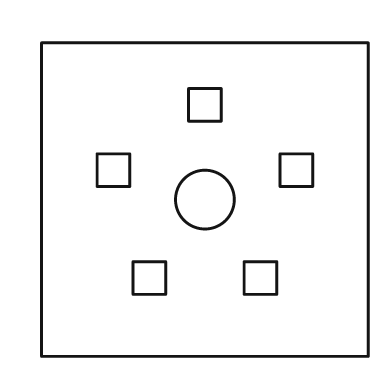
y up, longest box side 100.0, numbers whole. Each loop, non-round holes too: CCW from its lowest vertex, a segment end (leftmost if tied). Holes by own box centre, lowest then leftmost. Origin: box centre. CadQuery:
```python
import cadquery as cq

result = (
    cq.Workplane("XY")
    .moveTo(-50.0, -48.0)
    .lineTo(50.0, -48.0)
    .lineTo(50.0, 48.0)
    .lineTo(-50.0, 48.0)
    .close()
    .moveTo(-22.0, -29.0)
    .lineTo(-12.0, -29.0)
    .lineTo(-12.0, -19.0)
    .lineTo(-22.0, -19.0)
    .close()
    .moveTo(12.0, -29.0)
    .lineTo(22.0, -29.0)
    .lineTo(22.0, -19.0)
    .lineTo(12.0, -19.0)
    .close()
    .moveTo(0.0, 0.0)
    .circle(9.0)
    .moveTo(-33.0, 4.0)
    .lineTo(-23.0, 4.0)
    .lineTo(-23.0, 14.0)
    .lineTo(-33.0, 14.0)
    .close()
    .moveTo(23.0, 4.0)
    .lineTo(33.0, 4.0)
    .lineTo(33.0, 14.0)
    .lineTo(23.0, 14.0)
    .close()
    .moveTo(-5.0, 24.0)
    .lineTo(5.0, 24.0)
    .lineTo(5.0, 34.0)
    .lineTo(-5.0, 34.0)
    .close()
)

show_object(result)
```